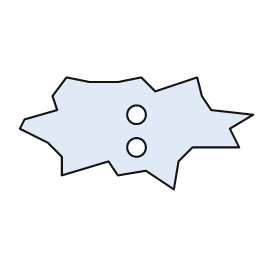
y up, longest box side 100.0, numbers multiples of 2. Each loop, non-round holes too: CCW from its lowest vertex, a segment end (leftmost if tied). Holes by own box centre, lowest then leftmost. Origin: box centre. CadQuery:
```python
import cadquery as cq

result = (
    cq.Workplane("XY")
    .moveTo(16.0, -24.0)
    .lineTo(18.0, -12.0)
    .lineTo(24.0, -6.0)
    .lineTo(44.0, -6.0)
    .lineTo(40.0, 2.0)
    .lineTo(50.0, 8.0)
    .lineTo(32.0, 10.0)
    .lineTo(28.0, 16.0)
    .lineTo(26.0, 24.0)
    .lineTo(8.0, 18.0)
    .lineTo(2.0, 24.0)
    .lineTo(-8.0, 22.0)
    .lineTo(-20.0, 22.0)
    .lineTo(-30.0, 24.0)
    .lineTo(-36.0, 16.0)
    .lineTo(-34.0, 10.0)
    .lineTo(-48.0, 6.0)
    .lineTo(-50.0, 2.0)
    .lineTo(-38.0, -4.0)
    .lineTo(-32.0, -10.0)
    .lineTo(-32.0, -18.0)
    .lineTo(-12.0, -12.0)
    .lineTo(-8.0, -18.0)
    .lineTo(4.0, -16.0)
    .close()
    .moveTo(0.0, -6.0)
    .circle(4.0)
    .moveTo(0.0, 8.0)
    .circle(4.0)
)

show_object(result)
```